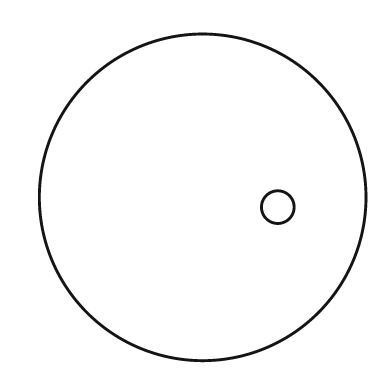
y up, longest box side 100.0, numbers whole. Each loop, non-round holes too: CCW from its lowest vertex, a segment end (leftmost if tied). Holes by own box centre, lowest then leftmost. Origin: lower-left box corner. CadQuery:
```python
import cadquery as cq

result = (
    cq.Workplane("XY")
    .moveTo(50.0, 50.0)
    .circle(50.0)
    .moveTo(73.0, 47.0)
    .circle(5.0)
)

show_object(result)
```